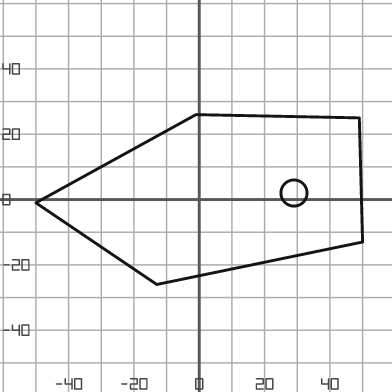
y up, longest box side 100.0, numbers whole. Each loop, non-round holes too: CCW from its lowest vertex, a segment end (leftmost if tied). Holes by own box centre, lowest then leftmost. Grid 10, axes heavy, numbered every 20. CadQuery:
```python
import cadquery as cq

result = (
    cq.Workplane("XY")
    .moveTo(-13.0, -26.0)
    .lineTo(50.0, -13.0)
    .lineTo(49.0, 25.0)
    .lineTo(-1.0, 26.0)
    .lineTo(-50.0, -1.0)
    .close()
    .moveTo(29.0, 2.0)
    .circle(4.0)
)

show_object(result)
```